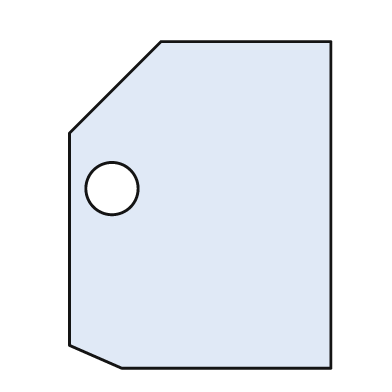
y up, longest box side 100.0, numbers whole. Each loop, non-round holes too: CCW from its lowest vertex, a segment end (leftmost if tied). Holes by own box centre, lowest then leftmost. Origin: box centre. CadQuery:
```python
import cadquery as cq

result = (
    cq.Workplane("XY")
    .moveTo(-24.0, -50.0)
    .lineTo(40.0, -50.0)
    .lineTo(40.0, 50.0)
    .lineTo(-12.0, 50.0)
    .lineTo(-40.0, 22.0)
    .lineTo(-40.0, -43.0)
    .close()
    .moveTo(-27.0, 5.0)
    .circle(8.0)
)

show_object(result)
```